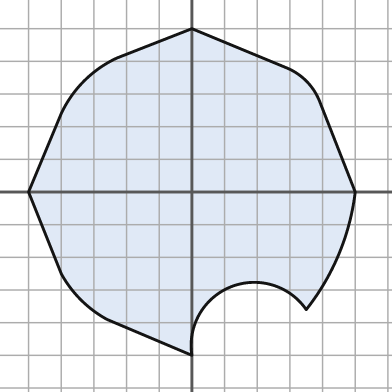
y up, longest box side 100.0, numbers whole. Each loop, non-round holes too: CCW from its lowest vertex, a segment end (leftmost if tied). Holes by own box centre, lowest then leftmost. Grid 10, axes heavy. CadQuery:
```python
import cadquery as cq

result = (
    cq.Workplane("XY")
    .moveTo(0.0, -50.0)
    .threePointArc((12.0, -29.0), (35.0, -36.0))
    .threePointArc((45.0, -19.0), (50.0, 0.0))
    .lineTo(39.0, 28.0)
    .threePointArc((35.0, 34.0), (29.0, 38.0))
    .lineTo(0.0, 50.0)
    .lineTo(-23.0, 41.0)
    .threePointArc((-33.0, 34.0), (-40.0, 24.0))
    .lineTo(-50.0, 0.0)
    .lineTo(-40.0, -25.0)
    .threePointArc((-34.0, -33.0), (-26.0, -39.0))
    .close()
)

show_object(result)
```